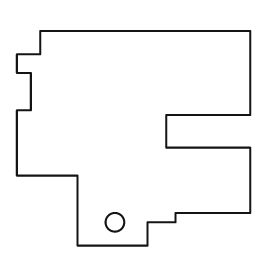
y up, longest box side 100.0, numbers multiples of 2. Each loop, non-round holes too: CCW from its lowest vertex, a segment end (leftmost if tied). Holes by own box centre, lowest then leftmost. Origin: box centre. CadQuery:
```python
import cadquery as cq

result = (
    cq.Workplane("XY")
    .moveTo(-24.0, -46.0)
    .lineTo(6.0, -46.0)
    .lineTo(6.0, -36.0)
    .lineTo(18.0, -36.0)
    .lineTo(18.0, -32.0)
    .lineTo(50.0, -32.0)
    .lineTo(50.0, -4.0)
    .lineTo(14.0, -4.0)
    .lineTo(14.0, 10.0)
    .lineTo(50.0, 10.0)
    .lineTo(50.0, 46.0)
    .lineTo(-40.0, 46.0)
    .lineTo(-40.0, 36.0)
    .lineTo(-50.0, 36.0)
    .lineTo(-50.0, 28.0)
    .lineTo(-44.0, 28.0)
    .lineTo(-44.0, 12.0)
    .lineTo(-50.0, 12.0)
    .lineTo(-50.0, -16.0)
    .lineTo(-24.0, -16.0)
    .close()
    .moveTo(-8.0, -36.0)
    .circle(4.0)
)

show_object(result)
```